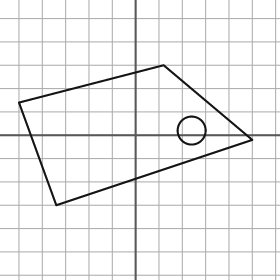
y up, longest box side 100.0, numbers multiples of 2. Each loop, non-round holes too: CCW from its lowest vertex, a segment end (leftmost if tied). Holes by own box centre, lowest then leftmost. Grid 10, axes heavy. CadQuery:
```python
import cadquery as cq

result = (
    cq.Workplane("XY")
    .moveTo(-34.0, -30.0)
    .lineTo(50.0, -2.0)
    .lineTo(12.0, 30.0)
    .lineTo(-50.0, 14.0)
    .close()
    .moveTo(24.0, 2.0)
    .circle(6.0)
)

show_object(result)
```